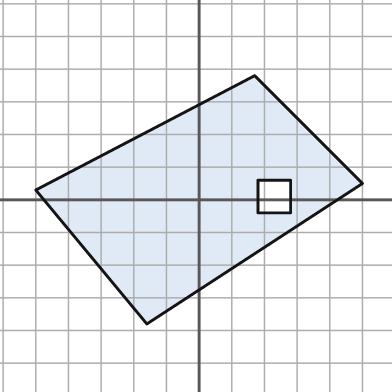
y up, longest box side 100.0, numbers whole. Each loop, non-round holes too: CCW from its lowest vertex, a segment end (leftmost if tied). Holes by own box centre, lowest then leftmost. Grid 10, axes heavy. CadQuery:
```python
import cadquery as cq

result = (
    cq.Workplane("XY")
    .moveTo(-16.0, -38.0)
    .lineTo(50.0, 5.0)
    .lineTo(17.0, 38.0)
    .lineTo(-50.0, 3.0)
    .close()
    .moveTo(18.0, -4.0)
    .lineTo(28.0, -4.0)
    .lineTo(28.0, 6.0)
    .lineTo(18.0, 6.0)
    .close()
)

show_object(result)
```